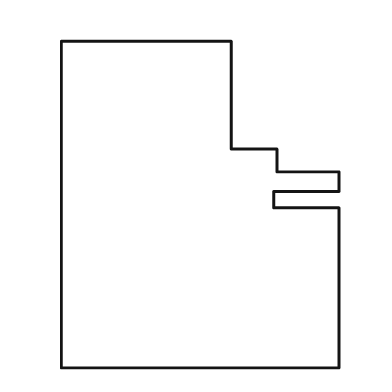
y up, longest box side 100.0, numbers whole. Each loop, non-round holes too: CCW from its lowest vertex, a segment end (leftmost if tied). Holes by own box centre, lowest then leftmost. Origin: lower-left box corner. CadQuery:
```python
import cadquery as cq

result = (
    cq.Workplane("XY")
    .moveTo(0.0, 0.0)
    .lineTo(85.0, 0.0)
    .lineTo(85.0, 49.0)
    .lineTo(65.0, 49.0)
    .lineTo(65.0, 54.0)
    .lineTo(85.0, 54.0)
    .lineTo(85.0, 60.0)
    .lineTo(66.0, 60.0)
    .lineTo(66.0, 67.0)
    .lineTo(52.0, 67.0)
    .lineTo(52.0, 100.0)
    .lineTo(0.0, 100.0)
    .close()
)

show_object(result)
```